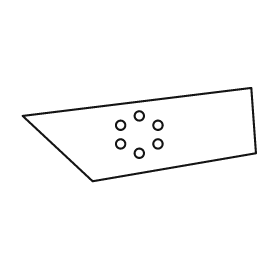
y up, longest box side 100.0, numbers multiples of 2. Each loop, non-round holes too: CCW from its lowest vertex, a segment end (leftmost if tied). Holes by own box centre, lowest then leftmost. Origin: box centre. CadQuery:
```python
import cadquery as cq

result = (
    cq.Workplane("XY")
    .moveTo(-20.0, -20.0)
    .lineTo(50.0, -8.0)
    .lineTo(48.0, 20.0)
    .lineTo(-50.0, 8.0)
    .close()
    .moveTo(0.0, -8.0)
    .circle(2.0)
    .moveTo(-8.0, -4.0)
    .circle(2.0)
    .moveTo(8.0, -4.0)
    .circle(2.0)
    .moveTo(-8.0, 4.0)
    .circle(2.0)
    .moveTo(8.0, 4.0)
    .circle(2.0)
    .moveTo(0.0, 8.0)
    .circle(2.0)
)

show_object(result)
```